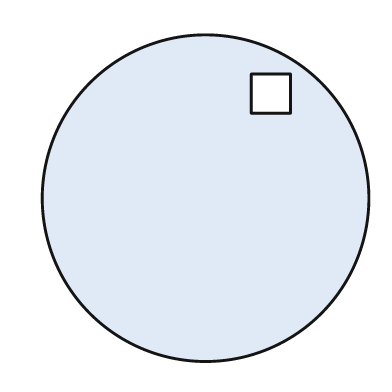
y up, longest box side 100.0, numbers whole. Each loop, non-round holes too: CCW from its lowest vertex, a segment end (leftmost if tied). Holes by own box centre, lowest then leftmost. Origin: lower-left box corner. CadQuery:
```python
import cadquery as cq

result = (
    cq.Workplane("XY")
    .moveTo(50.0, 50.0)
    .circle(50.0)
    .moveTo(64.0, 76.0)
    .lineTo(76.0, 76.0)
    .lineTo(76.0, 88.0)
    .lineTo(64.0, 88.0)
    .close()
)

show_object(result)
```